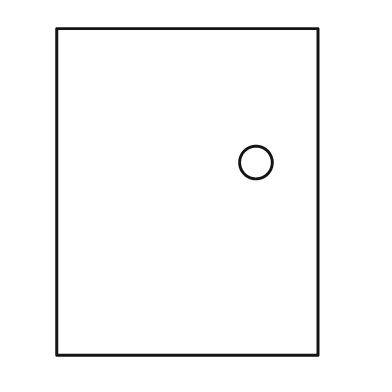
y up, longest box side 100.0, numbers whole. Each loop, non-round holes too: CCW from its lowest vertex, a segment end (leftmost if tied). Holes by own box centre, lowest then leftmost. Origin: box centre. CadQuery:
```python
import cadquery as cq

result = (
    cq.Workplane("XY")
    .moveTo(-40.0, -50.0)
    .lineTo(40.0, -50.0)
    .lineTo(40.0, 50.0)
    .lineTo(-40.0, 50.0)
    .close()
    .moveTo(21.0, 9.0)
    .circle(5.0)
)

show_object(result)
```